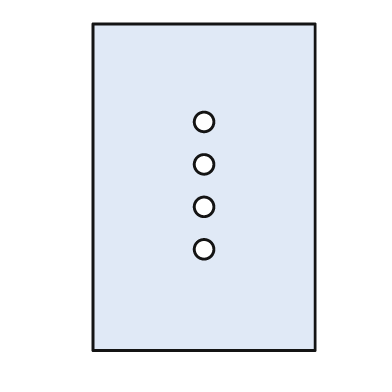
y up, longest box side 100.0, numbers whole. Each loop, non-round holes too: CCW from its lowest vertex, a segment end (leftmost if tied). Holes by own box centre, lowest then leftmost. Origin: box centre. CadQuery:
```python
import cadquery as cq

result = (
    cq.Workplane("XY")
    .moveTo(-34.0, -50.0)
    .lineTo(34.0, -50.0)
    .lineTo(34.0, 50.0)
    .lineTo(-34.0, 50.0)
    .close()
    .moveTo(0.0, -19.0)
    .circle(3.0)
    .moveTo(0.0, -6.0)
    .circle(3.0)
    .moveTo(0.0, 7.0)
    .circle(3.0)
    .moveTo(0.0, 20.0)
    .circle(3.0)
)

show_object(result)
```